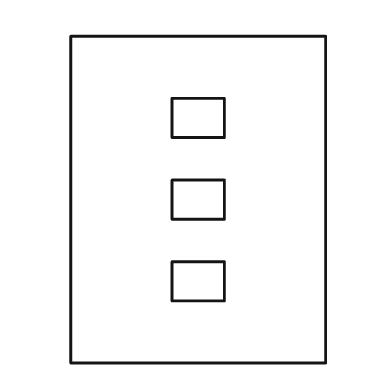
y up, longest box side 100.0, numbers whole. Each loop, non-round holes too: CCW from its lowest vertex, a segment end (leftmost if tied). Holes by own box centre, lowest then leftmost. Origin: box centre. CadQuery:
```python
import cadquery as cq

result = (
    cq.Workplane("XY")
    .moveTo(-39.0, -50.0)
    .lineTo(39.0, -50.0)
    .lineTo(39.0, 50.0)
    .lineTo(-39.0, 50.0)
    .close()
    .moveTo(-8.0, -31.0)
    .lineTo(8.0, -31.0)
    .lineTo(8.0, -19.0)
    .lineTo(-8.0, -19.0)
    .close()
    .moveTo(-8.0, -6.0)
    .lineTo(8.0, -6.0)
    .lineTo(8.0, 6.0)
    .lineTo(-8.0, 6.0)
    .close()
    .moveTo(-8.0, 19.0)
    .lineTo(8.0, 19.0)
    .lineTo(8.0, 31.0)
    .lineTo(-8.0, 31.0)
    .close()
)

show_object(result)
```